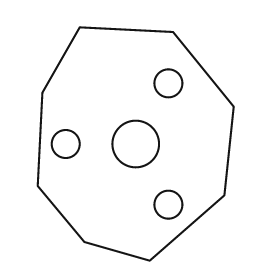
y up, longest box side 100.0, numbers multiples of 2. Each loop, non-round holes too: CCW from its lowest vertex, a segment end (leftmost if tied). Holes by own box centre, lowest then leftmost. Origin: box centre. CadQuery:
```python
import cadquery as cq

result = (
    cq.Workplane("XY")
    .moveTo(6.0, -50.0)
    .lineTo(38.0, -22.0)
    .lineTo(42.0, 16.0)
    .lineTo(16.0, 48.0)
    .lineTo(-24.0, 50.0)
    .lineTo(-40.0, 22.0)
    .lineTo(-42.0, -18.0)
    .lineTo(-22.0, -42.0)
    .close()
    .moveTo(14.0, -26.0)
    .circle(6.0)
    .moveTo(-30.0, 0.0)
    .circle(6.0)
    .moveTo(0.0, 0.0)
    .circle(10.0)
    .moveTo(14.0, 26.0)
    .circle(6.0)
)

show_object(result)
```